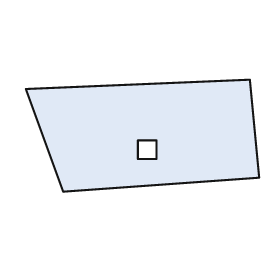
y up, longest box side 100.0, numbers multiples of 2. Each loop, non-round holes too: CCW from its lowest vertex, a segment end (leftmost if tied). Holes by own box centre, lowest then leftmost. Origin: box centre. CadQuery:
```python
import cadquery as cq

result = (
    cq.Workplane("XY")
    .moveTo(-34.0, -24.0)
    .lineTo(50.0, -18.0)
    .lineTo(46.0, 24.0)
    .lineTo(-50.0, 20.0)
    .close()
    .moveTo(-2.0, -10.0)
    .lineTo(6.0, -10.0)
    .lineTo(6.0, -2.0)
    .lineTo(-2.0, -2.0)
    .close()
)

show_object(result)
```